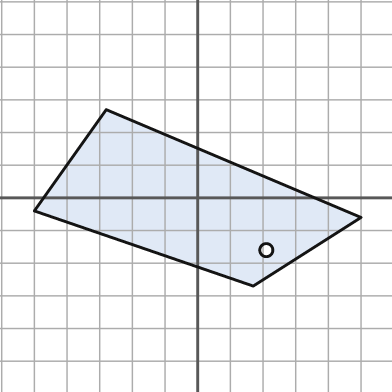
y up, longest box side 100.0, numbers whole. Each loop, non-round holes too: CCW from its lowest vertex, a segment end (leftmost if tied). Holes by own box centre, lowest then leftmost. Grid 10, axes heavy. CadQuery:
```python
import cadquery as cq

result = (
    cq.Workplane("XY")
    .moveTo(17.0, -27.0)
    .lineTo(50.0, -6.0)
    .lineTo(-28.0, 27.0)
    .lineTo(-50.0, -4.0)
    .close()
    .moveTo(21.0, -16.0)
    .circle(2.0)
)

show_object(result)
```